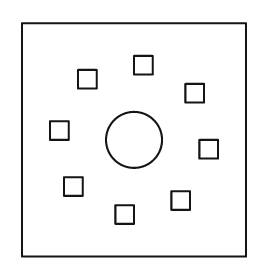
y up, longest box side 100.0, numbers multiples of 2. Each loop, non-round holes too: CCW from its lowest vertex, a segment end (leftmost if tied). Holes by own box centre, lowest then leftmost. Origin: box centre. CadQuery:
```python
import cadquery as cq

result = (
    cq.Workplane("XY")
    .moveTo(-48.0, -50.0)
    .lineTo(48.0, -50.0)
    .lineTo(48.0, 50.0)
    .lineTo(-48.0, 50.0)
    .close()
    .moveTo(-8.0, -36.0)
    .lineTo(0.0, -36.0)
    .lineTo(0.0, -28.0)
    .lineTo(-8.0, -28.0)
    .close()
    .moveTo(16.0, -30.0)
    .lineTo(24.0, -30.0)
    .lineTo(24.0, -22.0)
    .lineTo(16.0, -22.0)
    .close()
    .moveTo(-30.0, -24.0)
    .lineTo(-22.0, -24.0)
    .lineTo(-22.0, -16.0)
    .lineTo(-30.0, -16.0)
    .close()
    .moveTo(28.0, -8.0)
    .lineTo(36.0, -8.0)
    .lineTo(36.0, 0.0)
    .lineTo(28.0, 0.0)
    .close()
    .moveTo(0.0, 0.0)
    .circle(12.0)
    .moveTo(-36.0, 0.0)
    .lineTo(-28.0, 0.0)
    .lineTo(-28.0, 8.0)
    .lineTo(-36.0, 8.0)
    .close()
    .moveTo(22.0, 16.0)
    .lineTo(30.0, 16.0)
    .lineTo(30.0, 24.0)
    .lineTo(22.0, 24.0)
    .close()
    .moveTo(-24.0, 22.0)
    .lineTo(-16.0, 22.0)
    .lineTo(-16.0, 30.0)
    .lineTo(-24.0, 30.0)
    .close()
    .moveTo(0.0, 28.0)
    .lineTo(8.0, 28.0)
    .lineTo(8.0, 36.0)
    .lineTo(0.0, 36.0)
    .close()
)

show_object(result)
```